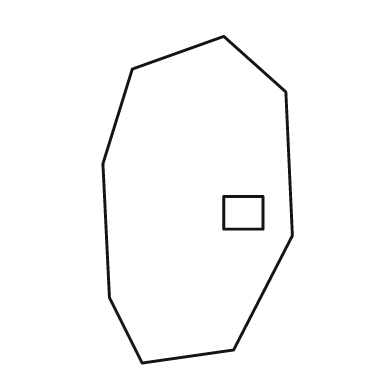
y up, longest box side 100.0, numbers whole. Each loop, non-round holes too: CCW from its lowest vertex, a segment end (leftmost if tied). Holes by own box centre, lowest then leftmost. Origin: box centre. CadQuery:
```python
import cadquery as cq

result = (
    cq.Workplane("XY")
    .moveTo(-17.0, -50.0)
    .lineTo(11.0, -46.0)
    .lineTo(29.0, -11.0)
    .lineTo(27.0, 33.0)
    .lineTo(8.0, 50.0)
    .lineTo(-20.0, 40.0)
    .lineTo(-29.0, 11.0)
    .lineTo(-27.0, -30.0)
    .close()
    .moveTo(8.0, -9.0)
    .lineTo(20.0, -9.0)
    .lineTo(20.0, 1.0)
    .lineTo(8.0, 1.0)
    .close()
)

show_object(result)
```